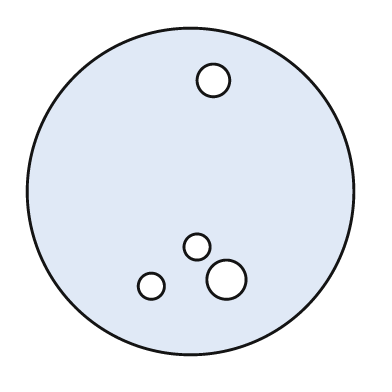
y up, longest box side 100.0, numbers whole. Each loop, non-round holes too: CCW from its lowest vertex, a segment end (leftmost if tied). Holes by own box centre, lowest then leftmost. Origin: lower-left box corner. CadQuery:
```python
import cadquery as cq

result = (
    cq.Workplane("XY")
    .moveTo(50.0, 50.0)
    .circle(50.0)
    .moveTo(38.0, 21.0)
    .circle(4.0)
    .moveTo(61.0, 23.0)
    .circle(6.0)
    .moveTo(52.0, 33.0)
    .circle(4.0)
    .moveTo(57.0, 84.0)
    .circle(5.0)
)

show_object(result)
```